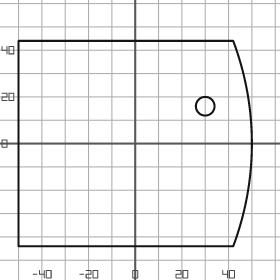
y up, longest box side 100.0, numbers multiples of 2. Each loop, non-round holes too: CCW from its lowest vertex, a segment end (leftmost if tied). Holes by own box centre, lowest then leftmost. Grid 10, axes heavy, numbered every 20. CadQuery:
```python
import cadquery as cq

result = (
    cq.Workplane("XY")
    .moveTo(-50.0, -44.0)
    .lineTo(42.0, -44.0)
    .threePointArc((50.0, 0.0), (42.0, 44.0))
    .lineTo(-50.0, 44.0)
    .close()
    .moveTo(30.0, 16.0)
    .circle(4.0)
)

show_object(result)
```